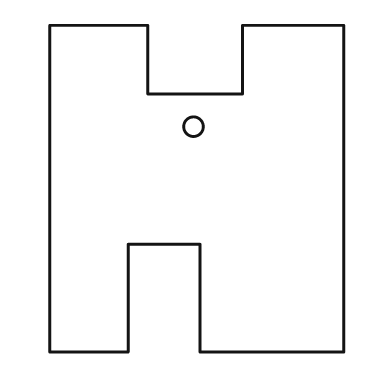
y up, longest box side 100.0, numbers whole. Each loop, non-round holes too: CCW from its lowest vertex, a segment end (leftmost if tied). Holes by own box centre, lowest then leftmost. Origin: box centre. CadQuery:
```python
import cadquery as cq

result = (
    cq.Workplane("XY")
    .moveTo(-45.0, -50.0)
    .lineTo(-21.0, -50.0)
    .lineTo(-21.0, -17.0)
    .lineTo(1.0, -17.0)
    .lineTo(1.0, -50.0)
    .lineTo(45.0, -50.0)
    .lineTo(45.0, 50.0)
    .lineTo(14.0, 50.0)
    .lineTo(14.0, 29.0)
    .lineTo(-15.0, 29.0)
    .lineTo(-15.0, 50.0)
    .lineTo(-45.0, 50.0)
    .close()
    .moveTo(-1.0, 19.0)
    .circle(3.0)
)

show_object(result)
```